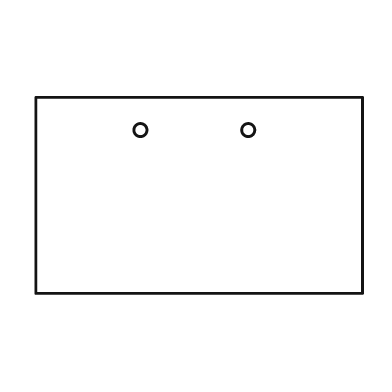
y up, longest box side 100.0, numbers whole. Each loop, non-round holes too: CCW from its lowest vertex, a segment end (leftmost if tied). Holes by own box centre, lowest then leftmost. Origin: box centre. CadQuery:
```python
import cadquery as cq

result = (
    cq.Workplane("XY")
    .moveTo(-50.0, -30.0)
    .lineTo(50.0, -30.0)
    .lineTo(50.0, 30.0)
    .lineTo(-50.0, 30.0)
    .close()
    .moveTo(-18.0, 20.0)
    .circle(2.0)
    .moveTo(15.0, 20.0)
    .circle(2.0)
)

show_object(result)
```